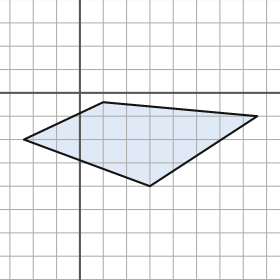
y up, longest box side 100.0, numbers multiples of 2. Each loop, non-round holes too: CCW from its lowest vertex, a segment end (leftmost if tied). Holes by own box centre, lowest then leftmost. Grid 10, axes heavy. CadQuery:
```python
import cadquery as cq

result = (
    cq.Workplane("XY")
    .moveTo(30.0, -40.0)
    .lineTo(76.0, -10.0)
    .lineTo(10.0, -4.0)
    .lineTo(-24.0, -20.0)
    .close()
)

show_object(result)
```